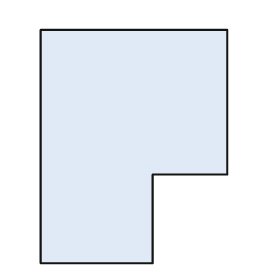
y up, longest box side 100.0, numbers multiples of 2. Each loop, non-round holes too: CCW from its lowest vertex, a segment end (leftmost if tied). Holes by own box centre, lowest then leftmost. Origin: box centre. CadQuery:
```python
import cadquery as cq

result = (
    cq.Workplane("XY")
    .moveTo(-40.0, -50.0)
    .lineTo(8.0, -50.0)
    .lineTo(8.0, -12.0)
    .lineTo(40.0, -12.0)
    .lineTo(40.0, 50.0)
    .lineTo(-40.0, 50.0)
    .close()
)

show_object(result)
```